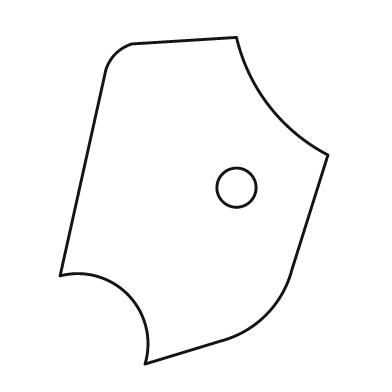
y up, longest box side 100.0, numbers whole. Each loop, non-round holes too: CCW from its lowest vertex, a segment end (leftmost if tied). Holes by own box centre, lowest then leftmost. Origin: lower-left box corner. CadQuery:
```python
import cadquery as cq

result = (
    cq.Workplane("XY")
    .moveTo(26.0, 0.0)
    .lineTo(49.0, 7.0)
    .threePointArc((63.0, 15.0), (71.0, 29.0))
    .lineTo(82.0, 64.0)
    .threePointArc((64.0, 79.0), (54.0, 100.0))
    .lineTo(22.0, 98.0)
    .threePointArc((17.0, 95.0), (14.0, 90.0))
    .lineTo(0.0, 27.0)
    .threePointArc((21.0, 21.0), (26.0, 0.0))
    .close()
    .moveTo(54.0, 54.0)
    .circle(6.0)
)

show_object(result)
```